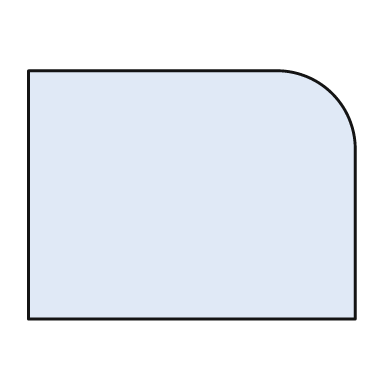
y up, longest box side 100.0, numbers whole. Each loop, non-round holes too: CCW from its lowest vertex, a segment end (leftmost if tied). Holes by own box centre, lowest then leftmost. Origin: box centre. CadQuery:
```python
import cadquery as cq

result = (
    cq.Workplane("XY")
    .moveTo(-50.0, -38.0)
    .lineTo(50.0, -38.0)
    .lineTo(50.0, 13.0)
    .threePointArc((43.0, 31.0), (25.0, 38.0))
    .lineTo(-50.0, 38.0)
    .close()
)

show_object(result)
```